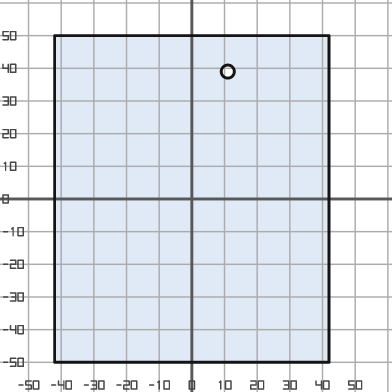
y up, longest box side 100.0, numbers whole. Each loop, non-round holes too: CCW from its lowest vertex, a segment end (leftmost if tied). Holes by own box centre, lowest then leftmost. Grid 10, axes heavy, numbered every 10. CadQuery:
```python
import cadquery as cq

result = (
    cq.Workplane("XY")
    .moveTo(-42.0, -50.0)
    .lineTo(42.0, -50.0)
    .lineTo(42.0, 50.0)
    .lineTo(-42.0, 50.0)
    .close()
    .moveTo(11.0, 39.0)
    .circle(2.0)
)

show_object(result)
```